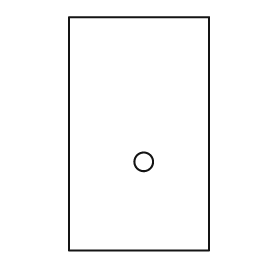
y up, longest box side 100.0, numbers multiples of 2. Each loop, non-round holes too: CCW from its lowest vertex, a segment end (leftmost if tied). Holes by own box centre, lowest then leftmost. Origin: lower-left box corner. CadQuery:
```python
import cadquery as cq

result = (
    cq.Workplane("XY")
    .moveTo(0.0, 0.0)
    .lineTo(60.0, 0.0)
    .lineTo(60.0, 100.0)
    .lineTo(0.0, 100.0)
    .close()
    .moveTo(32.0, 38.0)
    .circle(4.0)
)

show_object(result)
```